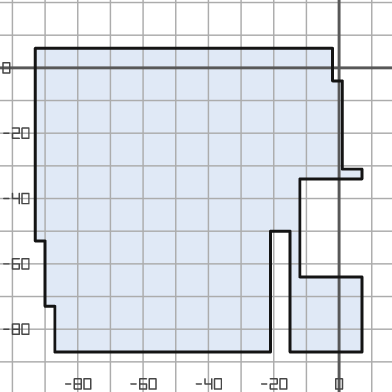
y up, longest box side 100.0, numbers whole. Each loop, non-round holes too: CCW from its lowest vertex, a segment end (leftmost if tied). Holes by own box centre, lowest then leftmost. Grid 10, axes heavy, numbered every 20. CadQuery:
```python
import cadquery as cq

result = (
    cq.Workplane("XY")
    .moveTo(-87.0, -87.0)
    .lineTo(-21.0, -87.0)
    .lineTo(-21.0, -50.0)
    .lineTo(-15.0, -50.0)
    .lineTo(-15.0, -87.0)
    .lineTo(7.0, -87.0)
    .lineTo(7.0, -64.0)
    .lineTo(-12.0, -64.0)
    .lineTo(-12.0, -34.0)
    .lineTo(7.0, -34.0)
    .lineTo(7.0, -31.0)
    .lineTo(1.0, -31.0)
    .lineTo(1.0, -4.0)
    .lineTo(-2.0, -4.0)
    .lineTo(-2.0, 6.0)
    .lineTo(-93.0, 6.0)
    .lineTo(-93.0, -53.0)
    .lineTo(-90.0, -53.0)
    .lineTo(-90.0, -73.0)
    .lineTo(-87.0, -73.0)
    .close()
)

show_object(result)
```